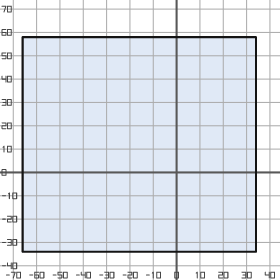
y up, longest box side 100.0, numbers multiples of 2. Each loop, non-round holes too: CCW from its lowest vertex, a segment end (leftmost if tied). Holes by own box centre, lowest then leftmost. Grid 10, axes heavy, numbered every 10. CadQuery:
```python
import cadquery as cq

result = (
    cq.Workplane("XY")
    .moveTo(-66.0, -34.0)
    .lineTo(34.0, -34.0)
    .lineTo(34.0, 58.0)
    .lineTo(-66.0, 58.0)
    .close()
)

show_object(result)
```